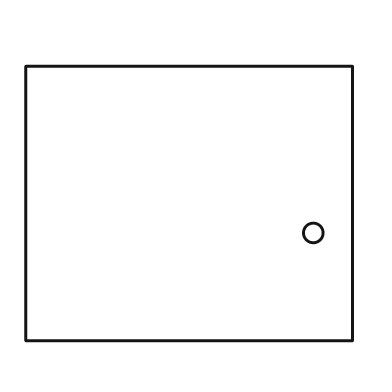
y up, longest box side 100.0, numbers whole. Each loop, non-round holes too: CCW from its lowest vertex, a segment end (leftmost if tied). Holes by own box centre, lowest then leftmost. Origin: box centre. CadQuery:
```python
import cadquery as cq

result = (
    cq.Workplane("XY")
    .moveTo(-50.0, -42.0)
    .lineTo(50.0, -42.0)
    .lineTo(50.0, 42.0)
    .lineTo(-50.0, 42.0)
    .close()
    .moveTo(38.0, -9.0)
    .circle(3.0)
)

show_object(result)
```